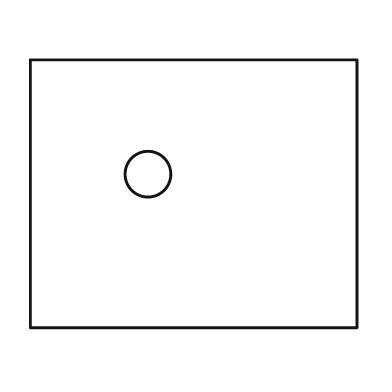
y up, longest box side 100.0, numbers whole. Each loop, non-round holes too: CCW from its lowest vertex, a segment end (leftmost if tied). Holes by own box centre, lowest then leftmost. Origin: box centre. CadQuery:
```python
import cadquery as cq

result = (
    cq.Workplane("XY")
    .moveTo(-50.0, -41.0)
    .lineTo(50.0, -41.0)
    .lineTo(50.0, 41.0)
    .lineTo(-50.0, 41.0)
    .close()
    .moveTo(-14.0, 6.0)
    .circle(7.0)
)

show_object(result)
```